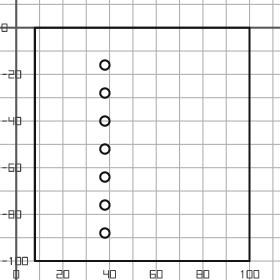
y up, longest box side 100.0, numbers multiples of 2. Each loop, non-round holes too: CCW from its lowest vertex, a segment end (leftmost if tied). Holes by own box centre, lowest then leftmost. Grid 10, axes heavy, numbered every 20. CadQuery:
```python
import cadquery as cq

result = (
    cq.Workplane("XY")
    .moveTo(8.0, -100.0)
    .lineTo(100.0, -100.0)
    .lineTo(100.0, 0.0)
    .lineTo(8.0, 0.0)
    .close()
    .moveTo(38.0, -88.0)
    .circle(2.0)
    .moveTo(38.0, -76.0)
    .circle(2.0)
    .moveTo(38.0, -64.0)
    .circle(2.0)
    .moveTo(38.0, -52.0)
    .circle(2.0)
    .moveTo(38.0, -40.0)
    .circle(2.0)
    .moveTo(38.0, -28.0)
    .circle(2.0)
    .moveTo(38.0, -16.0)
    .circle(2.0)
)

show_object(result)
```